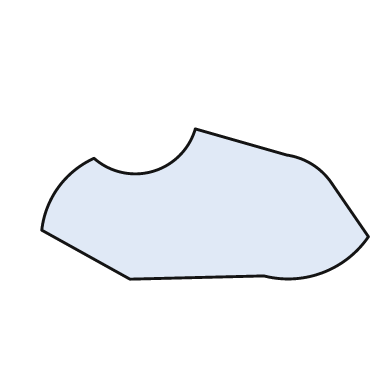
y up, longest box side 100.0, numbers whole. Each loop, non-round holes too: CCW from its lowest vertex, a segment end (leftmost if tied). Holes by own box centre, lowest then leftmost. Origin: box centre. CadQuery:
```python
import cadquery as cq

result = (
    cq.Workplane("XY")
    .moveTo(-23.0, -23.0)
    .lineTo(18.0, -22.0)
    .threePointArc((36.0, -21.0), (50.0, -10.0))
    .lineTo(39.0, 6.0)
    .threePointArc((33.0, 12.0), (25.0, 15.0))
    .lineTo(-3.0, 23.0)
    .threePointArc((-16.0, 10.0), (-34.0, 14.0))
    .threePointArc((-45.0, 5.0), (-50.0, -8.0))
    .close()
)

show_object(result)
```